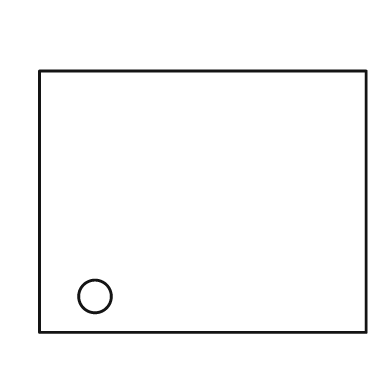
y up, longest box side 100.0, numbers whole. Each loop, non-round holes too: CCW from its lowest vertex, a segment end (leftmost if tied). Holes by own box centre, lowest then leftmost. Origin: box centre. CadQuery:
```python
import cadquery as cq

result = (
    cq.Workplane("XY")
    .moveTo(-50.0, -40.0)
    .lineTo(50.0, -40.0)
    .lineTo(50.0, 40.0)
    .lineTo(-50.0, 40.0)
    .close()
    .moveTo(-33.0, -29.0)
    .circle(5.0)
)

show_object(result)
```